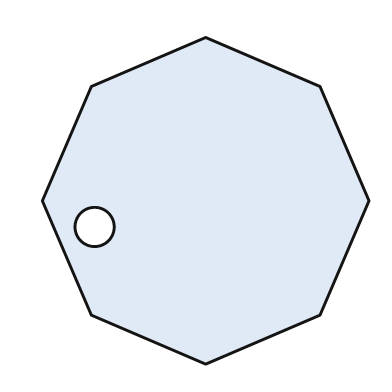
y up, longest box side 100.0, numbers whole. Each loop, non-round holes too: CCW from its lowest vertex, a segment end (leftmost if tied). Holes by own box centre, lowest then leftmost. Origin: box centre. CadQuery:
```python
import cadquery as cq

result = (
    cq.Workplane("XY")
    .moveTo(0.0, -50.0)
    .lineTo(35.0, -35.0)
    .lineTo(50.0, 0.0)
    .lineTo(35.0, 35.0)
    .lineTo(0.0, 50.0)
    .lineTo(-35.0, 35.0)
    .lineTo(-50.0, 0.0)
    .lineTo(-35.0, -35.0)
    .close()
    .moveTo(-34.0, -8.0)
    .circle(6.0)
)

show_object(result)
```